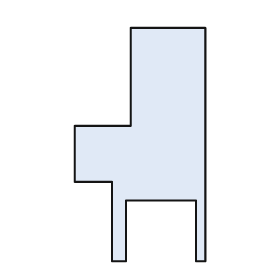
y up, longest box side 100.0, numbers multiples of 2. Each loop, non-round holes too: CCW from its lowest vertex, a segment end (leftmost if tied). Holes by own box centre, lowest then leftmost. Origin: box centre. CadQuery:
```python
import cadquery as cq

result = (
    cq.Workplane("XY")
    .moveTo(-12.0, -50.0)
    .lineTo(-6.0, -50.0)
    .lineTo(-6.0, -24.0)
    .lineTo(24.0, -24.0)
    .lineTo(24.0, -50.0)
    .lineTo(28.0, -50.0)
    .lineTo(28.0, 50.0)
    .lineTo(-4.0, 50.0)
    .lineTo(-4.0, 8.0)
    .lineTo(-28.0, 8.0)
    .lineTo(-28.0, -16.0)
    .lineTo(-12.0, -16.0)
    .close()
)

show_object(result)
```